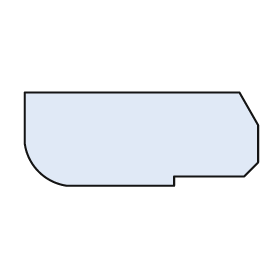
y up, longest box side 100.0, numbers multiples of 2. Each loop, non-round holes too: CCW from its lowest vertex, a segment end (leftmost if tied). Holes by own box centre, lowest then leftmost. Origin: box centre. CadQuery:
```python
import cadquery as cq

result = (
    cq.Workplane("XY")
    .moveTo(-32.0, -20.0)
    .lineTo(14.0, -20.0)
    .lineTo(14.0, -16.0)
    .lineTo(44.0, -16.0)
    .lineTo(50.0, -10.0)
    .lineTo(50.0, 6.0)
    .lineTo(42.0, 20.0)
    .lineTo(-50.0, 20.0)
    .lineTo(-50.0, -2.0)
    .threePointArc((-44.0, -14.0), (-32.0, -20.0))
    .close()
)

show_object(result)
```